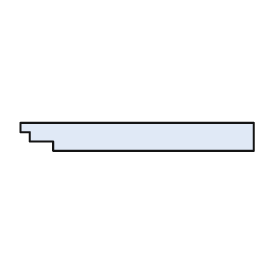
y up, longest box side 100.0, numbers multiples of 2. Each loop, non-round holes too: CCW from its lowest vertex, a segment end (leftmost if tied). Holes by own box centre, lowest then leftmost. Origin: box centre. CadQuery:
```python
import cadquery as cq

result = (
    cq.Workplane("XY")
    .moveTo(-36.0, -6.0)
    .lineTo(50.0, -6.0)
    .lineTo(50.0, 6.0)
    .lineTo(-50.0, 6.0)
    .lineTo(-50.0, 2.0)
    .lineTo(-46.0, 2.0)
    .lineTo(-46.0, -2.0)
    .lineTo(-36.0, -2.0)
    .close()
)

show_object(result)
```